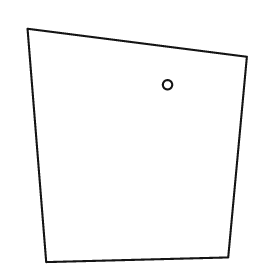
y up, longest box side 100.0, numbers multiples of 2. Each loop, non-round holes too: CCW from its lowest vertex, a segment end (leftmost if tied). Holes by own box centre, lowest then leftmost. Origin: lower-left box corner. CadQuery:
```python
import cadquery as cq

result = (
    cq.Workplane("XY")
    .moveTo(8.0, 0.0)
    .lineTo(86.0, 2.0)
    .lineTo(94.0, 88.0)
    .lineTo(0.0, 100.0)
    .close()
    .moveTo(60.0, 76.0)
    .circle(2.0)
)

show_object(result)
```